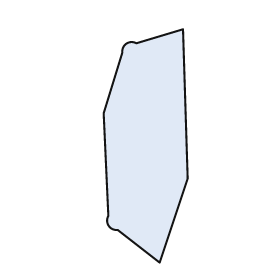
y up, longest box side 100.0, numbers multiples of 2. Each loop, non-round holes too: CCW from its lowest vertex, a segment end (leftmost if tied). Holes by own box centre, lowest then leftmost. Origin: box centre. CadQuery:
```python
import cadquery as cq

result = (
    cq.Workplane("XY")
    .moveTo(6.0, -50.0)
    .lineTo(18.0, -14.0)
    .lineTo(16.0, 50.0)
    .lineTo(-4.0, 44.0)
    .threePointArc((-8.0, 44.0), (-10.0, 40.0))
    .lineTo(-18.0, 14.0)
    .lineTo(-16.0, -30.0)
    .threePointArc((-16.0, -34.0), (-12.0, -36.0))
    .close()
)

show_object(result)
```